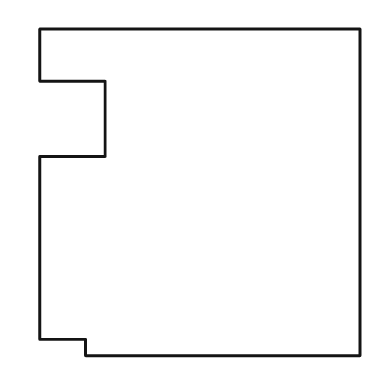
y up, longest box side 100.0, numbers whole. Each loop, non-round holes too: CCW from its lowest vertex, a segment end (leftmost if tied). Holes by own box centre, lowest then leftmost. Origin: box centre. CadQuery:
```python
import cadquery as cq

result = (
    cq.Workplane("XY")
    .moveTo(-35.0, -50.0)
    .lineTo(49.0, -50.0)
    .lineTo(49.0, 50.0)
    .lineTo(-49.0, 50.0)
    .lineTo(-49.0, 34.0)
    .lineTo(-29.0, 34.0)
    .lineTo(-29.0, 11.0)
    .lineTo(-49.0, 11.0)
    .lineTo(-49.0, -45.0)
    .lineTo(-35.0, -45.0)
    .close()
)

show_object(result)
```